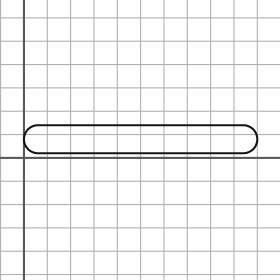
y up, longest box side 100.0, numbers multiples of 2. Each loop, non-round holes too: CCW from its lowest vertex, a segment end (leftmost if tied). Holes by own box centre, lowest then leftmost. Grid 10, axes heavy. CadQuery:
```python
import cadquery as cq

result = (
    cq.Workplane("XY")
    .moveTo(6.0, 2.0)
    .lineTo(94.0, 2.0)
    .threePointArc((100.0, 8.0), (94.0, 14.0))
    .lineTo(6.0, 14.0)
    .threePointArc((0.0, 8.0), (6.0, 2.0))
    .close()
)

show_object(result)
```